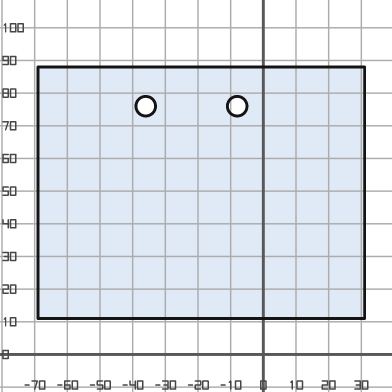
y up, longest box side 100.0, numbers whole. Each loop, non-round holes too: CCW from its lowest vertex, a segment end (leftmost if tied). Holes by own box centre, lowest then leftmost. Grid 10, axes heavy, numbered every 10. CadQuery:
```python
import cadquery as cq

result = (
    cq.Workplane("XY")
    .moveTo(-69.0, 11.0)
    .lineTo(31.0, 11.0)
    .lineTo(31.0, 88.0)
    .lineTo(-69.0, 88.0)
    .close()
    .moveTo(-36.0, 76.0)
    .circle(3.0)
    .moveTo(-8.0, 76.0)
    .circle(3.0)
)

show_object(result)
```